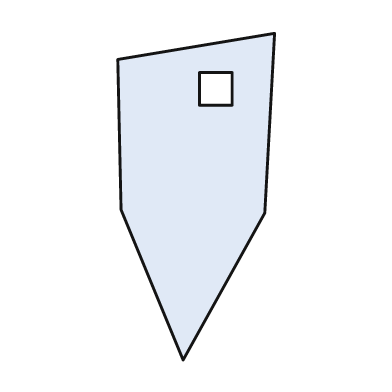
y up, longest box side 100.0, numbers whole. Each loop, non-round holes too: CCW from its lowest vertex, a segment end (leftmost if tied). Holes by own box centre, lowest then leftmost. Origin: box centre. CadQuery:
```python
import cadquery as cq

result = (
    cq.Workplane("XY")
    .moveTo(-4.0, -50.0)
    .lineTo(21.0, -5.0)
    .lineTo(24.0, 50.0)
    .lineTo(-24.0, 42.0)
    .lineTo(-23.0, -4.0)
    .close()
    .moveTo(1.0, 28.0)
    .lineTo(11.0, 28.0)
    .lineTo(11.0, 38.0)
    .lineTo(1.0, 38.0)
    .close()
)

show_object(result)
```